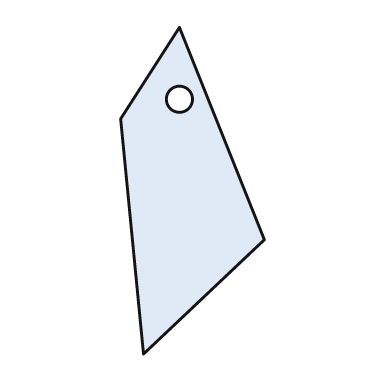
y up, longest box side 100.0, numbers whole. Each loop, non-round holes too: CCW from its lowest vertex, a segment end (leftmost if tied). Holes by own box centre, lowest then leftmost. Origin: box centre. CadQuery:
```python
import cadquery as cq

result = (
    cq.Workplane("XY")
    .moveTo(-15.0, -50.0)
    .lineTo(22.0, -15.0)
    .lineTo(-4.0, 50.0)
    .lineTo(-22.0, 22.0)
    .close()
    .moveTo(-4.0, 28.0)
    .circle(4.0)
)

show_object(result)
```